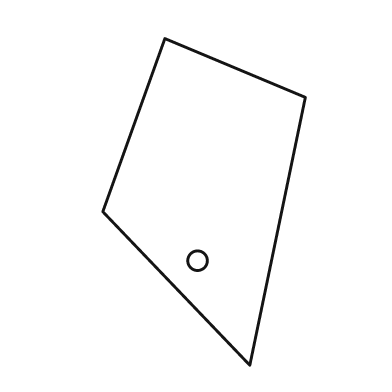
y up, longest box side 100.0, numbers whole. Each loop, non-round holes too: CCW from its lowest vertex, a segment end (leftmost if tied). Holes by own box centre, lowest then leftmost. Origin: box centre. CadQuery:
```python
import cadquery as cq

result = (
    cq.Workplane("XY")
    .moveTo(14.0, -50.0)
    .lineTo(31.0, 32.0)
    .lineTo(-12.0, 50.0)
    .lineTo(-31.0, -3.0)
    .close()
    .moveTo(-2.0, -18.0)
    .circle(3.0)
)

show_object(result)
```